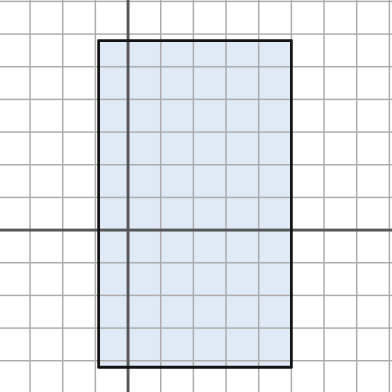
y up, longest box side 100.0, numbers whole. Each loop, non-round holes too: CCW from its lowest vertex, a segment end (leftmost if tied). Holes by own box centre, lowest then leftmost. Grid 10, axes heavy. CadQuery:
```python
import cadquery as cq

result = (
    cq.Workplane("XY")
    .moveTo(-9.0, -42.0)
    .lineTo(50.0, -42.0)
    .lineTo(50.0, 58.0)
    .lineTo(-9.0, 58.0)
    .close()
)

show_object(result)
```